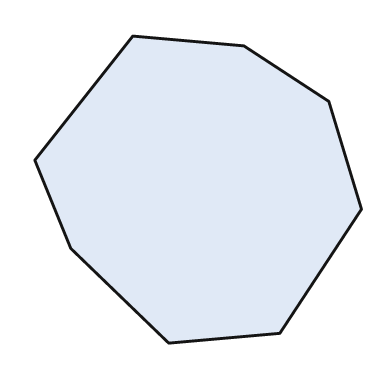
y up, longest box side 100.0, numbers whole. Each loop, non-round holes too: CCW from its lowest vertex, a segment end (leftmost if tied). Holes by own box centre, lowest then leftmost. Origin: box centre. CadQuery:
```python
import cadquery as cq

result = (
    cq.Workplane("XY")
    .moveTo(-9.0, -47.0)
    .lineTo(25.0, -44.0)
    .lineTo(50.0, -6.0)
    .lineTo(40.0, 27.0)
    .lineTo(14.0, 44.0)
    .lineTo(-20.0, 47.0)
    .lineTo(-50.0, 9.0)
    .lineTo(-39.0, -18.0)
    .close()
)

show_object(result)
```